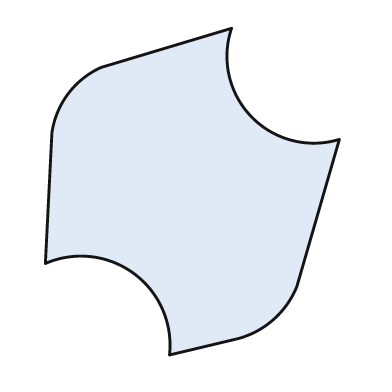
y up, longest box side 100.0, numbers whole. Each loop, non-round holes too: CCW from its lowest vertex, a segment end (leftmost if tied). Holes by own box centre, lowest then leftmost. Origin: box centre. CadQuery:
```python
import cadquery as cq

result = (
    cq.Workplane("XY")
    .moveTo(-7.0, -50.0)
    .lineTo(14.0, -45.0)
    .threePointArc((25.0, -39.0), (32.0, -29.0))
    .lineTo(45.0, 16.0)
    .threePointArc((18.0, 23.0), (12.0, 50.0))
    .lineTo(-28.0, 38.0)
    .threePointArc((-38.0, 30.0), (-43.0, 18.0))
    .lineTo(-45.0, -22.0)
    .threePointArc((-18.0, -25.0), (-7.0, -50.0))
    .close()
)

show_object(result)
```